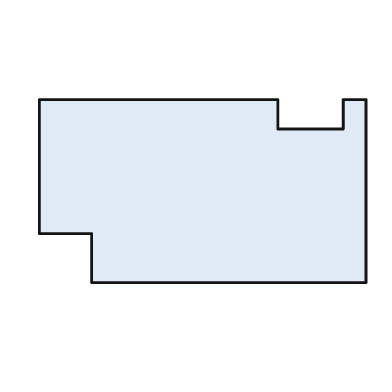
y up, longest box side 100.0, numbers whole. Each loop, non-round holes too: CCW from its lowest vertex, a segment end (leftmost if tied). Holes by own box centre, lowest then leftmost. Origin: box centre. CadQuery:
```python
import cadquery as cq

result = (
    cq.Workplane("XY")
    .moveTo(-34.0, -28.0)
    .lineTo(50.0, -28.0)
    .lineTo(50.0, 28.0)
    .lineTo(43.0, 28.0)
    .lineTo(43.0, 19.0)
    .lineTo(23.0, 19.0)
    .lineTo(23.0, 28.0)
    .lineTo(-50.0, 28.0)
    .lineTo(-50.0, -13.0)
    .lineTo(-34.0, -13.0)
    .close()
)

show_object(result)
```